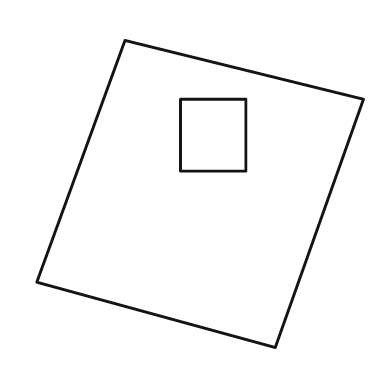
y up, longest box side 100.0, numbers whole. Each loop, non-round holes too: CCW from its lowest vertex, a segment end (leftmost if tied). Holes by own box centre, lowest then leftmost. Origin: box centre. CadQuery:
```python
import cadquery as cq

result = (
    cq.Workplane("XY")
    .moveTo(23.0, -47.0)
    .lineTo(50.0, 29.0)
    .lineTo(-23.0, 47.0)
    .lineTo(-50.0, -27.0)
    .close()
    .moveTo(-6.0, 7.0)
    .lineTo(14.0, 7.0)
    .lineTo(14.0, 29.0)
    .lineTo(-6.0, 29.0)
    .close()
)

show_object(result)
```